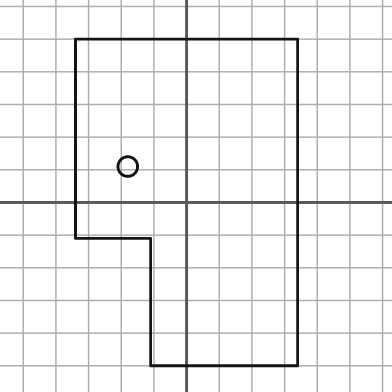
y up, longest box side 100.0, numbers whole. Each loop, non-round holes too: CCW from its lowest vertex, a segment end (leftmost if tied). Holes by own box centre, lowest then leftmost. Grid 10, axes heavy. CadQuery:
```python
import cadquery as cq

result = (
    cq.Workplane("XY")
    .moveTo(-11.0, -50.0)
    .lineTo(34.0, -50.0)
    .lineTo(34.0, 50.0)
    .lineTo(-34.0, 50.0)
    .lineTo(-34.0, -11.0)
    .lineTo(-11.0, -11.0)
    .close()
    .moveTo(-18.0, 11.0)
    .circle(3.0)
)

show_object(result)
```